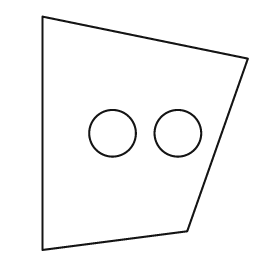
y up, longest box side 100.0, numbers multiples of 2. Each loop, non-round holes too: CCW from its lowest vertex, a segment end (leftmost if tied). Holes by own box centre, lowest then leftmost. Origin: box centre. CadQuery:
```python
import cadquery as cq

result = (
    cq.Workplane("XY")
    .moveTo(-44.0, -50.0)
    .lineTo(18.0, -42.0)
    .lineTo(44.0, 32.0)
    .lineTo(-44.0, 50.0)
    .close()
    .moveTo(-14.0, 0.0)
    .circle(10.0)
    .moveTo(14.0, 0.0)
    .circle(10.0)
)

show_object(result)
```